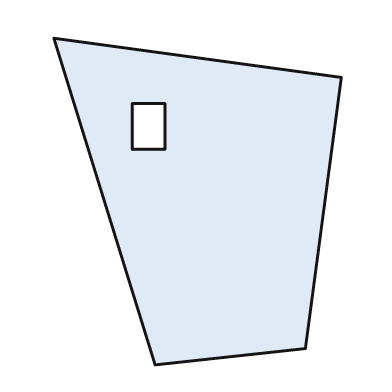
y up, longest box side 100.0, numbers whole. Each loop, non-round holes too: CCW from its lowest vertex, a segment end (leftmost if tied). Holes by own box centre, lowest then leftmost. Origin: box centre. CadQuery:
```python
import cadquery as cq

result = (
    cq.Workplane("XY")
    .moveTo(-13.0, -50.0)
    .lineTo(33.0, -45.0)
    .lineTo(44.0, 38.0)
    .lineTo(-44.0, 50.0)
    .close()
    .moveTo(-20.0, 16.0)
    .lineTo(-10.0, 16.0)
    .lineTo(-10.0, 30.0)
    .lineTo(-20.0, 30.0)
    .close()
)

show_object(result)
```